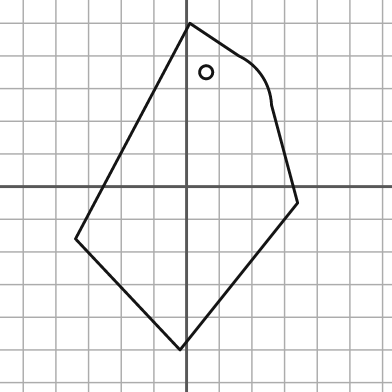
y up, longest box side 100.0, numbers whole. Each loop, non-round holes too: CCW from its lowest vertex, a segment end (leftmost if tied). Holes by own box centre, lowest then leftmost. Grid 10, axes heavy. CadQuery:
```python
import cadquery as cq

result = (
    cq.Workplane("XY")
    .moveTo(-2.0, -50.0)
    .lineTo(34.0, -5.0)
    .lineTo(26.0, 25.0)
    .threePointArc((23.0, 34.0), (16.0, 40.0))
    .lineTo(1.0, 50.0)
    .lineTo(-34.0, -16.0)
    .close()
    .moveTo(6.0, 35.0)
    .circle(2.0)
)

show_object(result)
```